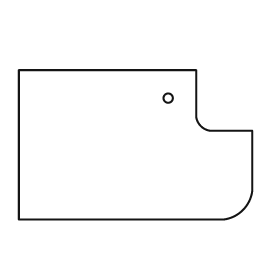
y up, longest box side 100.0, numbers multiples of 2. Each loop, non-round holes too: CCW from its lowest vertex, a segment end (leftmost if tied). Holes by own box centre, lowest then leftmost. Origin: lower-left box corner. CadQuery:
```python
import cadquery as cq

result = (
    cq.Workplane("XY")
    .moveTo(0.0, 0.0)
    .lineTo(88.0, 0.0)
    .threePointArc((96.0, 4.0), (100.0, 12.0))
    .lineTo(100.0, 38.0)
    .lineTo(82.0, 38.0)
    .threePointArc((78.0, 40.0), (76.0, 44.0))
    .lineTo(76.0, 64.0)
    .lineTo(0.0, 64.0)
    .close()
    .moveTo(64.0, 52.0)
    .circle(2.0)
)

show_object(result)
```